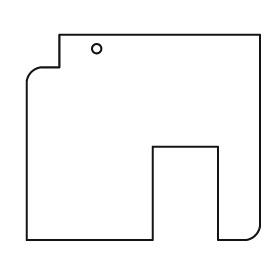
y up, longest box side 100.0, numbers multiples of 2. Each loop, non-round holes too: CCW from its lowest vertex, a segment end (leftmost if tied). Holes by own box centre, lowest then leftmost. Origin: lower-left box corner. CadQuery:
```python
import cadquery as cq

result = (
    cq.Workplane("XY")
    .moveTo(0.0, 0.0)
    .lineTo(54.0, 0.0)
    .lineTo(54.0, 40.0)
    .lineTo(82.0, 40.0)
    .lineTo(82.0, 0.0)
    .lineTo(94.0, 0.0)
    .threePointArc((98.0, 2.0), (100.0, 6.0))
    .lineTo(100.0, 88.0)
    .lineTo(14.0, 88.0)
    .lineTo(14.0, 74.0)
    .lineTo(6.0, 74.0)
    .threePointArc((2.0, 72.0), (0.0, 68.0))
    .close()
    .moveTo(30.0, 82.0)
    .circle(2.0)
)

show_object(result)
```